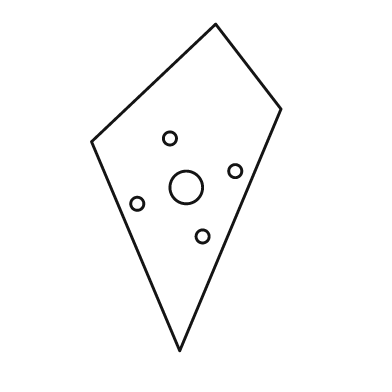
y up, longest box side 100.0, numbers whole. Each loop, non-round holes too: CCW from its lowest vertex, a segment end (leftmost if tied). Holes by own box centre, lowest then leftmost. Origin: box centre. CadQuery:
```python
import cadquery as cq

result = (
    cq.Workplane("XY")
    .moveTo(-2.0, -50.0)
    .lineTo(29.0, 24.0)
    .lineTo(9.0, 50.0)
    .lineTo(-29.0, 14.0)
    .close()
    .moveTo(5.0, -15.0)
    .circle(2.0)
    .moveTo(-15.0, -5.0)
    .circle(2.0)
    .moveTo(0.0, 0.0)
    .circle(5.0)
    .moveTo(15.0, 5.0)
    .circle(2.0)
    .moveTo(-5.0, 15.0)
    .circle(2.0)
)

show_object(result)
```